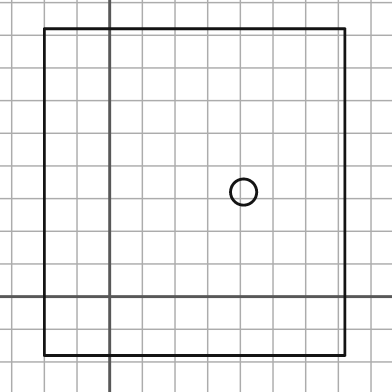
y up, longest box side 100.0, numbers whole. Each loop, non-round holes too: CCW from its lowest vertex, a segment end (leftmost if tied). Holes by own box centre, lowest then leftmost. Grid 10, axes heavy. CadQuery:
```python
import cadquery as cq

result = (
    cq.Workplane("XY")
    .moveTo(-20.0, -18.0)
    .lineTo(72.0, -18.0)
    .lineTo(72.0, 82.0)
    .lineTo(-20.0, 82.0)
    .close()
    .moveTo(41.0, 32.0)
    .circle(4.0)
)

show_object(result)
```